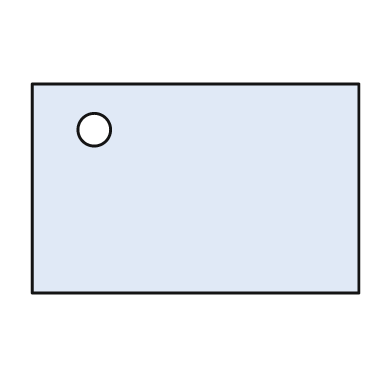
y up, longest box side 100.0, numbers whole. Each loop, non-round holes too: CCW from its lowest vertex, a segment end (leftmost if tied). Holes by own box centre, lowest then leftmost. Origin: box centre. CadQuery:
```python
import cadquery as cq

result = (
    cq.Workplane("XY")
    .moveTo(-50.0, -32.0)
    .lineTo(50.0, -32.0)
    .lineTo(50.0, 32.0)
    .lineTo(-50.0, 32.0)
    .close()
    .moveTo(-31.0, 18.0)
    .circle(5.0)
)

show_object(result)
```